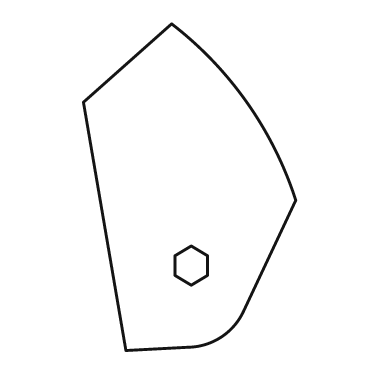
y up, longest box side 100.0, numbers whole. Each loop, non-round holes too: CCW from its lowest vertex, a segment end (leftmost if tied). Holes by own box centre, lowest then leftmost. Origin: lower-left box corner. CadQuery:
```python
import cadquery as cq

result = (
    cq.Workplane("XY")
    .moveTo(13.0, 0.0)
    .lineTo(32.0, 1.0)
    .threePointArc((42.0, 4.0), (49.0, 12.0))
    .lineTo(65.0, 46.0)
    .threePointArc((50.0, 76.0), (27.0, 100.0))
    .lineTo(0.0, 76.0)
    .close()
    .moveTo(33.0, 20.0)
    .lineTo(38.0, 23.0)
    .lineTo(38.0, 29.0)
    .lineTo(33.0, 32.0)
    .lineTo(28.0, 29.0)
    .lineTo(28.0, 23.0)
    .close()
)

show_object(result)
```